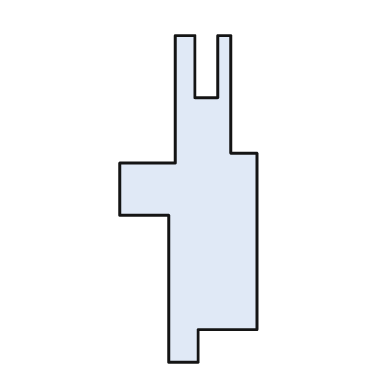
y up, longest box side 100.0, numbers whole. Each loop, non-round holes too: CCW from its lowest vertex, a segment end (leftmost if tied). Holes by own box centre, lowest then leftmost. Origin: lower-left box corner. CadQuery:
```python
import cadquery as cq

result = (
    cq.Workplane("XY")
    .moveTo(15.0, 0.0)
    .lineTo(24.0, 0.0)
    .lineTo(24.0, 10.0)
    .lineTo(42.0, 10.0)
    .lineTo(42.0, 64.0)
    .lineTo(34.0, 64.0)
    .lineTo(34.0, 100.0)
    .lineTo(30.0, 100.0)
    .lineTo(30.0, 81.0)
    .lineTo(23.0, 81.0)
    .lineTo(23.0, 100.0)
    .lineTo(17.0, 100.0)
    .lineTo(17.0, 61.0)
    .lineTo(0.0, 61.0)
    .lineTo(0.0, 45.0)
    .lineTo(15.0, 45.0)
    .close()
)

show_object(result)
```